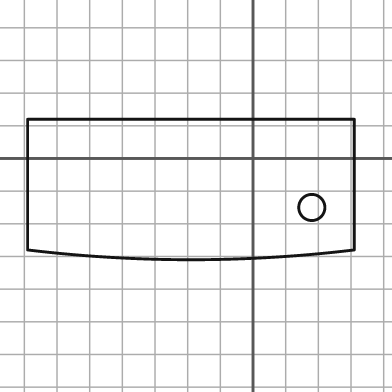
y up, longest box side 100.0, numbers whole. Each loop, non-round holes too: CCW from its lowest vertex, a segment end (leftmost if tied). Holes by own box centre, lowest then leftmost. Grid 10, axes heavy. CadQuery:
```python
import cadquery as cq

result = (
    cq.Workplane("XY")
    .moveTo(-69.0, -28.0)
    .threePointArc((-19.0, -31.0), (31.0, -28.0))
    .lineTo(31.0, 12.0)
    .lineTo(-69.0, 12.0)
    .close()
    .moveTo(18.0, -15.0)
    .circle(4.0)
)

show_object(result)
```